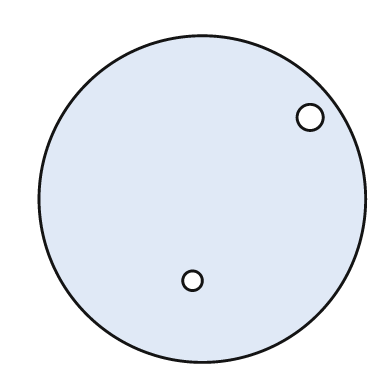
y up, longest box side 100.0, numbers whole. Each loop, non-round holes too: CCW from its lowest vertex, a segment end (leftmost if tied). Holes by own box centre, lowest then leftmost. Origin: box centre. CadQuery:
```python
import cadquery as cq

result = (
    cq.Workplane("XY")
    .moveTo(0.0, 0.0)
    .circle(50.0)
    .moveTo(-3.0, -25.0)
    .circle(3.0)
    .moveTo(33.0, 25.0)
    .circle(4.0)
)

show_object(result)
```